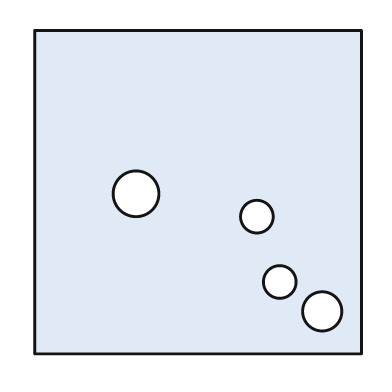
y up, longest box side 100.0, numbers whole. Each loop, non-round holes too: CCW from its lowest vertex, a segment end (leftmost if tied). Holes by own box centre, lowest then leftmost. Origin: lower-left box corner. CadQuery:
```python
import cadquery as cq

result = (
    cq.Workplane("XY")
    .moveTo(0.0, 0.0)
    .lineTo(100.0, 0.0)
    .lineTo(100.0, 99.0)
    .lineTo(0.0, 99.0)
    .close()
    .moveTo(88.0, 13.0)
    .circle(6.0)
    .moveTo(75.0, 22.0)
    .circle(5.0)
    .moveTo(68.0, 42.0)
    .circle(5.0)
    .moveTo(31.0, 49.0)
    .circle(7.0)
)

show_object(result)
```